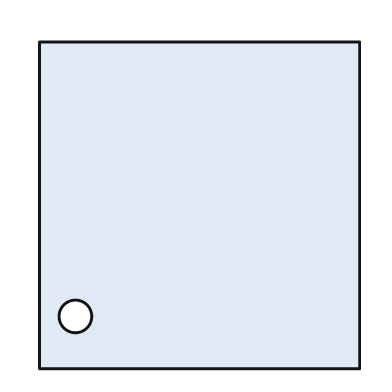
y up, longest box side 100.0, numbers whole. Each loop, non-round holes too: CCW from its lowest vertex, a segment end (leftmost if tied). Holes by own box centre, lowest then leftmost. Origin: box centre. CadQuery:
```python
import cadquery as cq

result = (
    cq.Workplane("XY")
    .moveTo(-49.0, -50.0)
    .lineTo(49.0, -50.0)
    .lineTo(49.0, 50.0)
    .lineTo(-49.0, 50.0)
    .close()
    .moveTo(-38.0, -34.0)
    .circle(5.0)
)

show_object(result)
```